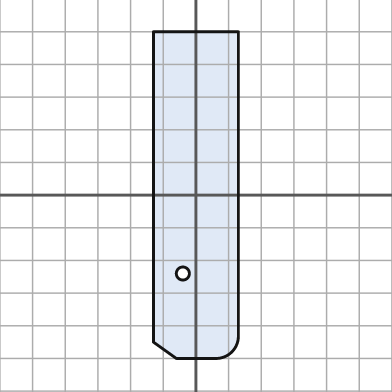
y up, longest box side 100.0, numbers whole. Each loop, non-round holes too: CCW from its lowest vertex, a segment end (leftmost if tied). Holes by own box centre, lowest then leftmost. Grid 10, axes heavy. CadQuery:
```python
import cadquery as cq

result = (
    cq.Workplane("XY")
    .moveTo(-6.0, -50.0)
    .lineTo(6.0, -50.0)
    .threePointArc((11.0, -48.0), (13.0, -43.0))
    .lineTo(13.0, 50.0)
    .lineTo(-13.0, 50.0)
    .lineTo(-13.0, -45.0)
    .close()
    .moveTo(-4.0, -24.0)
    .circle(2.0)
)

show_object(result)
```